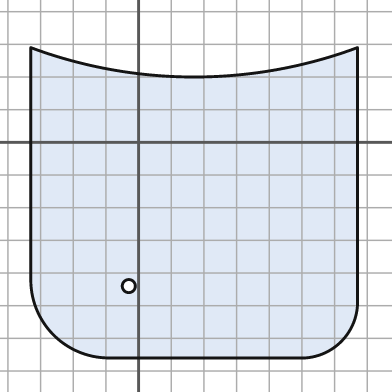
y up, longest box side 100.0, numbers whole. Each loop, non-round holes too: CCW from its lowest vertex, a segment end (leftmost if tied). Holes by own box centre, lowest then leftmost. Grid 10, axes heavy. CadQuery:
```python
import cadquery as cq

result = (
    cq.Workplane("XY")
    .moveTo(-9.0, -66.0)
    .lineTo(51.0, -66.0)
    .threePointArc((62.0, -61.0), (67.0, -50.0))
    .lineTo(67.0, 29.0)
    .threePointArc((17.0, 20.0), (-33.0, 29.0))
    .lineTo(-33.0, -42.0)
    .threePointArc((-26.0, -59.0), (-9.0, -66.0))
    .close()
    .moveTo(-3.0, -44.0)
    .circle(2.0)
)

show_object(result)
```